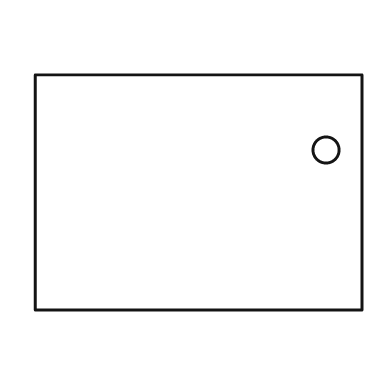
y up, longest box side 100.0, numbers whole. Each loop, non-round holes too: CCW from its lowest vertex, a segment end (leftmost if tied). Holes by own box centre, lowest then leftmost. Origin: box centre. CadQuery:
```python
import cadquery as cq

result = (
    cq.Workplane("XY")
    .moveTo(-50.0, -36.0)
    .lineTo(50.0, -36.0)
    .lineTo(50.0, 36.0)
    .lineTo(-50.0, 36.0)
    .close()
    .moveTo(39.0, 13.0)
    .circle(4.0)
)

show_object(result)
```